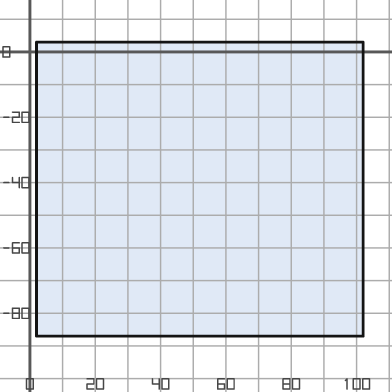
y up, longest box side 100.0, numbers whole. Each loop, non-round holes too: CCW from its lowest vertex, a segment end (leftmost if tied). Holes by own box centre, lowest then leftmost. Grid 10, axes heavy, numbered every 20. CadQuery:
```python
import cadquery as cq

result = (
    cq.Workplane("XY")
    .moveTo(2.0, -87.0)
    .lineTo(102.0, -87.0)
    .lineTo(102.0, 3.0)
    .lineTo(2.0, 3.0)
    .close()
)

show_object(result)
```